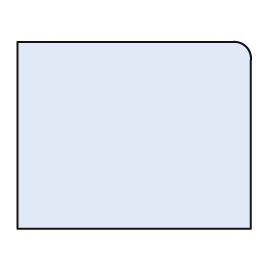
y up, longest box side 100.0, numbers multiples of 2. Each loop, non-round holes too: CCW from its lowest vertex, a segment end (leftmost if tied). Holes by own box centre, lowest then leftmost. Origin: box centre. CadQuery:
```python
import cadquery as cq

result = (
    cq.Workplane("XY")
    .moveTo(-50.0, -40.0)
    .lineTo(50.0, -40.0)
    .lineTo(50.0, 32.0)
    .threePointArc((48.0, 38.0), (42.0, 40.0))
    .lineTo(-50.0, 40.0)
    .close()
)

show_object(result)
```